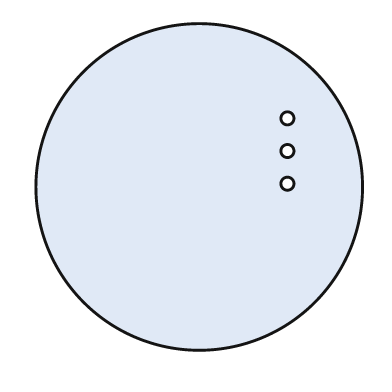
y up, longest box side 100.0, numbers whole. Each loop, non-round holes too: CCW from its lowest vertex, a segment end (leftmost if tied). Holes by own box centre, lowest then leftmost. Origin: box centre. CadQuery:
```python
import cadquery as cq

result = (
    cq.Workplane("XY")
    .moveTo(0.0, 0.0)
    .circle(50.0)
    .moveTo(27.0, 1.0)
    .circle(2.0)
    .moveTo(27.0, 11.0)
    .circle(2.0)
    .moveTo(27.0, 21.0)
    .circle(2.0)
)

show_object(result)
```